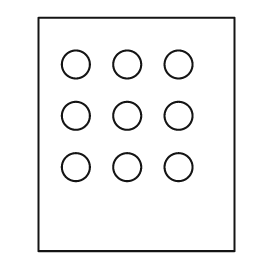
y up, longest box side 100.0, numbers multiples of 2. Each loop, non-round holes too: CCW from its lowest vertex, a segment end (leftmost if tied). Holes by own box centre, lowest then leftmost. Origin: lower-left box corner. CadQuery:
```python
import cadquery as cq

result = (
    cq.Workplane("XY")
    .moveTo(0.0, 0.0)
    .lineTo(84.0, 0.0)
    .lineTo(84.0, 100.0)
    .lineTo(0.0, 100.0)
    .close()
    .moveTo(16.0, 36.0)
    .circle(6.0)
    .moveTo(38.0, 36.0)
    .circle(6.0)
    .moveTo(60.0, 36.0)
    .circle(6.0)
    .moveTo(16.0, 58.0)
    .circle(6.0)
    .moveTo(38.0, 58.0)
    .circle(6.0)
    .moveTo(60.0, 58.0)
    .circle(6.0)
    .moveTo(16.0, 80.0)
    .circle(6.0)
    .moveTo(38.0, 80.0)
    .circle(6.0)
    .moveTo(60.0, 80.0)
    .circle(6.0)
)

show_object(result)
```